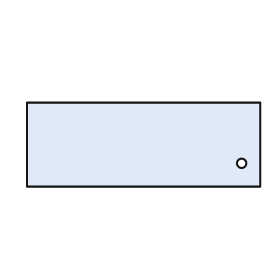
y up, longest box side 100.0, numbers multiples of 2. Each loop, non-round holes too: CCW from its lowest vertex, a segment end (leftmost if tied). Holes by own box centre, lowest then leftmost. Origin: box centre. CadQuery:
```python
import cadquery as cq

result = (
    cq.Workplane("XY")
    .moveTo(-50.0, -18.0)
    .lineTo(50.0, -18.0)
    .lineTo(50.0, 18.0)
    .lineTo(-50.0, 18.0)
    .close()
    .moveTo(42.0, -8.0)
    .circle(2.0)
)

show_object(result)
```